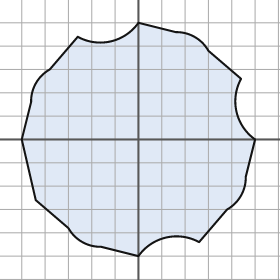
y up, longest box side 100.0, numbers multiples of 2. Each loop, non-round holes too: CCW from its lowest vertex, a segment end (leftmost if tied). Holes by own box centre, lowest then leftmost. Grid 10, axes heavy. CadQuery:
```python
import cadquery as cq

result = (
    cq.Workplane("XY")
    .moveTo(0.0, -50.0)
    .threePointArc((12.0, -42.0), (26.0, -44.0))
    .lineTo(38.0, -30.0)
    .threePointArc((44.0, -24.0), (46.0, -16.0))
    .lineTo(50.0, 0.0)
    .threePointArc((42.0, 12.0), (44.0, 26.0))
    .lineTo(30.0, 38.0)
    .threePointArc((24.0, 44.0), (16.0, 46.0))
    .lineTo(0.0, 50.0)
    .threePointArc((-12.0, 42.0), (-26.0, 44.0))
    .lineTo(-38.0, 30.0)
    .threePointArc((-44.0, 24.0), (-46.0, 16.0))
    .lineTo(-50.0, 0.0)
    .lineTo(-44.0, -26.0)
    .lineTo(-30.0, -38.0)
    .threePointArc((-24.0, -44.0), (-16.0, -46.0))
    .close()
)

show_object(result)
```